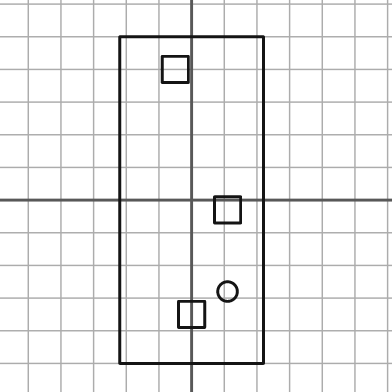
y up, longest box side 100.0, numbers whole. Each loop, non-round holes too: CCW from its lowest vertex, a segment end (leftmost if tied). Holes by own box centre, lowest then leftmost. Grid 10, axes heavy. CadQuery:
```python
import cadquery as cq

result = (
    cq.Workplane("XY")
    .moveTo(-22.0, -50.0)
    .lineTo(22.0, -50.0)
    .lineTo(22.0, 50.0)
    .lineTo(-22.0, 50.0)
    .close()
    .moveTo(-4.0, -39.0)
    .lineTo(4.0, -39.0)
    .lineTo(4.0, -31.0)
    .lineTo(-4.0, -31.0)
    .close()
    .moveTo(11.0, -28.0)
    .circle(3.0)
    .moveTo(7.0, -7.0)
    .lineTo(15.0, -7.0)
    .lineTo(15.0, 1.0)
    .lineTo(7.0, 1.0)
    .close()
    .moveTo(-9.0, 36.0)
    .lineTo(-1.0, 36.0)
    .lineTo(-1.0, 44.0)
    .lineTo(-9.0, 44.0)
    .close()
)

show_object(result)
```